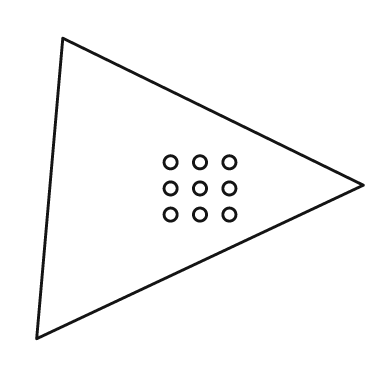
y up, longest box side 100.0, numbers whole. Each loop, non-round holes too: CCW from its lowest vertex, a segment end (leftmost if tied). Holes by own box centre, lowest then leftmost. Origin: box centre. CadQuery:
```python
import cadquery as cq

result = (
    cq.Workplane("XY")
    .moveTo(-50.0, -46.0)
    .lineTo(50.0, 1.0)
    .lineTo(-42.0, 46.0)
    .close()
    .moveTo(-9.0, -8.0)
    .circle(2.0)
    .moveTo(0.0, -8.0)
    .circle(2.0)
    .moveTo(9.0, -8.0)
    .circle(2.0)
    .moveTo(-9.0, 0.0)
    .circle(2.0)
    .moveTo(0.0, 0.0)
    .circle(2.0)
    .moveTo(9.0, 0.0)
    .circle(2.0)
    .moveTo(-9.0, 8.0)
    .circle(2.0)
    .moveTo(0.0, 8.0)
    .circle(2.0)
    .moveTo(9.0, 8.0)
    .circle(2.0)
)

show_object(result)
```